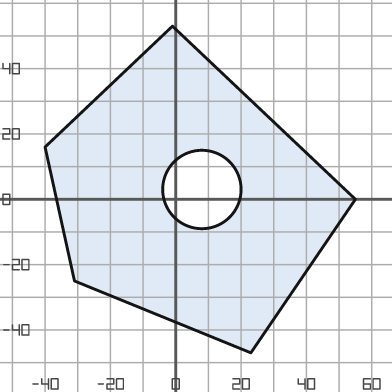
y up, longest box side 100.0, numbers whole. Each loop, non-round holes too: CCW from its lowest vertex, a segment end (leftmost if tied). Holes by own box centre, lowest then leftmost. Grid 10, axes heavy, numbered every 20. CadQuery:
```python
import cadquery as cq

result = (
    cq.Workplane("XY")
    .moveTo(23.0, -47.0)
    .lineTo(55.0, 0.0)
    .lineTo(-1.0, 53.0)
    .lineTo(-40.0, 16.0)
    .lineTo(-31.0, -25.0)
    .close()
    .moveTo(8.0, 3.0)
    .circle(12.0)
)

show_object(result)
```